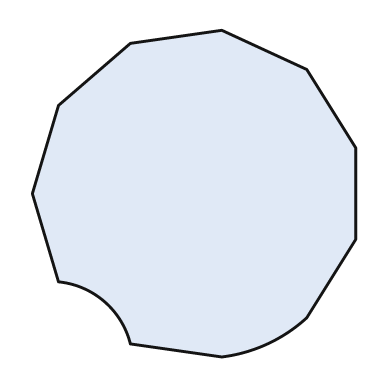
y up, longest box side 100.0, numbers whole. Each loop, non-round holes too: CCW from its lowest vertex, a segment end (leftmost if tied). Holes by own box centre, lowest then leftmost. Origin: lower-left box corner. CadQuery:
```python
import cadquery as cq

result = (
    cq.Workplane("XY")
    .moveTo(58.0, 0.0)
    .threePointArc((72.0, 4.0), (84.0, 12.0))
    .lineTo(99.0, 36.0)
    .lineTo(99.0, 64.0)
    .lineTo(84.0, 88.0)
    .lineTo(58.0, 100.0)
    .lineTo(30.0, 96.0)
    .lineTo(8.0, 77.0)
    .lineTo(0.0, 50.0)
    .lineTo(8.0, 23.0)
    .threePointArc((22.0, 17.0), (30.0, 4.0))
    .close()
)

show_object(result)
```